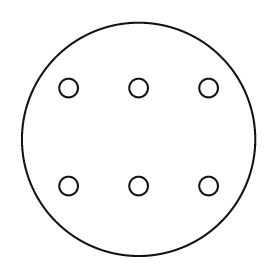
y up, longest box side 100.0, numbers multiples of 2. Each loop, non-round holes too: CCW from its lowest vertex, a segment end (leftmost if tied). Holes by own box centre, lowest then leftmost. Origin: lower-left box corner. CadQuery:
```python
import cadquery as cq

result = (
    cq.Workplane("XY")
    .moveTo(50.0, 50.0)
    .circle(50.0)
    .moveTo(20.0, 30.0)
    .circle(4.0)
    .moveTo(50.0, 30.0)
    .circle(4.0)
    .moveTo(80.0, 30.0)
    .circle(4.0)
    .moveTo(20.0, 72.0)
    .circle(4.0)
    .moveTo(50.0, 72.0)
    .circle(4.0)
    .moveTo(80.0, 72.0)
    .circle(4.0)
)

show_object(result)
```